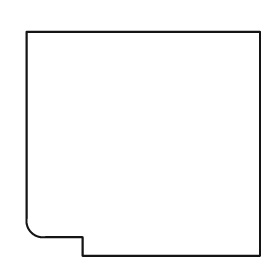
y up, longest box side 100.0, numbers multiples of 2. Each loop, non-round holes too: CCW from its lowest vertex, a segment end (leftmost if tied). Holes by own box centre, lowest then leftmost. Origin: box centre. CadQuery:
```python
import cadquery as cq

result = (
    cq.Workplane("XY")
    .moveTo(-26.0, -48.0)
    .lineTo(50.0, -48.0)
    .lineTo(50.0, 48.0)
    .lineTo(-50.0, 48.0)
    .lineTo(-50.0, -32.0)
    .threePointArc((-48.0, -38.0), (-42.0, -40.0))
    .lineTo(-26.0, -40.0)
    .close()
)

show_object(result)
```